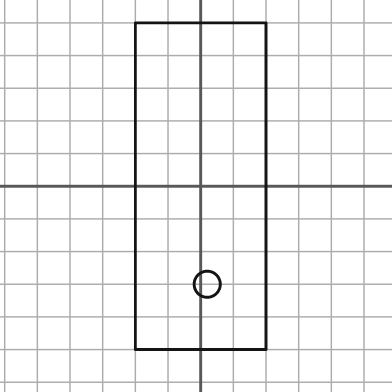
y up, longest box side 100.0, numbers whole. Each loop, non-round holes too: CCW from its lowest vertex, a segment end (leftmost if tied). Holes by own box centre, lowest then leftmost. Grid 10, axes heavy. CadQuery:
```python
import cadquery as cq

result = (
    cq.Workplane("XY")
    .moveTo(-20.0, -50.0)
    .lineTo(20.0, -50.0)
    .lineTo(20.0, 50.0)
    .lineTo(-20.0, 50.0)
    .close()
    .moveTo(2.0, -30.0)
    .circle(4.0)
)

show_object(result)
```